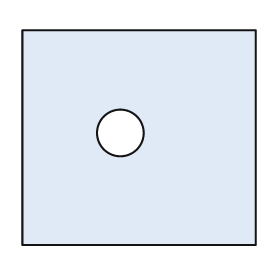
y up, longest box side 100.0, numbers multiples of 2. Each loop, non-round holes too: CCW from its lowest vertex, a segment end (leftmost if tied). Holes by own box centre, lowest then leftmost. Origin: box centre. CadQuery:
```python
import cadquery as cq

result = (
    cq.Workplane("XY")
    .moveTo(-50.0, -46.0)
    .lineTo(50.0, -46.0)
    .lineTo(50.0, 46.0)
    .lineTo(-50.0, 46.0)
    .close()
    .moveTo(-8.0, 2.0)
    .circle(10.0)
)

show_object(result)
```